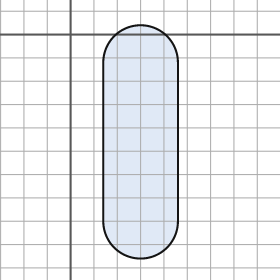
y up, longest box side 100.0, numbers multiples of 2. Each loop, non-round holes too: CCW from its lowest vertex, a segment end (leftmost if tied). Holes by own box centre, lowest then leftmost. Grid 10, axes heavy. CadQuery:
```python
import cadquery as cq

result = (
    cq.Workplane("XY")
    .moveTo(14.0, -80.0)
    .threePointArc((30.0, -96.0), (46.0, -80.0))
    .lineTo(46.0, -12.0)
    .threePointArc((30.0, 4.0), (14.0, -12.0))
    .close()
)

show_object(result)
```